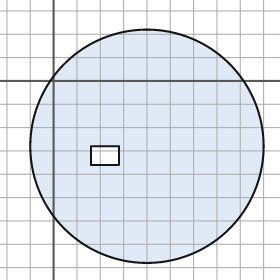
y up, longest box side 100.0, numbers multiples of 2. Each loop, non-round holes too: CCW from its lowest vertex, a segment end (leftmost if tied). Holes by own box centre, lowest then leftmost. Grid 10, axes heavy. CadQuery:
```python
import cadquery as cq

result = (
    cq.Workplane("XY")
    .moveTo(40.0, -28.0)
    .circle(50.0)
    .moveTo(16.0, -36.0)
    .lineTo(28.0, -36.0)
    .lineTo(28.0, -28.0)
    .lineTo(16.0, -28.0)
    .close()
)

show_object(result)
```